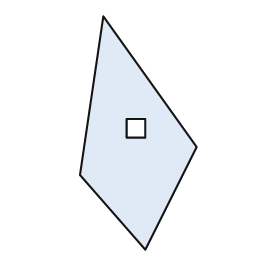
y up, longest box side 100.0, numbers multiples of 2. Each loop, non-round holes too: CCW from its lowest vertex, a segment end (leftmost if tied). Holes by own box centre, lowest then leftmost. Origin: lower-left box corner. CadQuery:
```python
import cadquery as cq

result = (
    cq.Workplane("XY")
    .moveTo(28.0, 0.0)
    .lineTo(50.0, 44.0)
    .lineTo(10.0, 100.0)
    .lineTo(0.0, 32.0)
    .close()
    .moveTo(20.0, 48.0)
    .lineTo(28.0, 48.0)
    .lineTo(28.0, 56.0)
    .lineTo(20.0, 56.0)
    .close()
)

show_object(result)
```